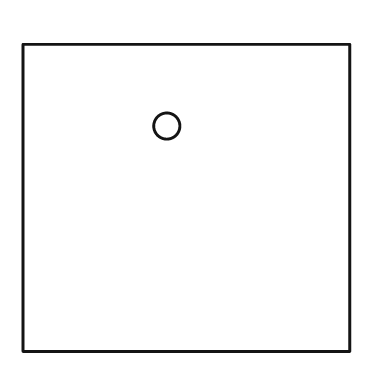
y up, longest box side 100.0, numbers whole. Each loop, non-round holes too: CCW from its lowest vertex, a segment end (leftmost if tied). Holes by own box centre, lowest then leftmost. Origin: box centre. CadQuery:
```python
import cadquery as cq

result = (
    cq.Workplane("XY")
    .moveTo(-50.0, -47.0)
    .lineTo(50.0, -47.0)
    .lineTo(50.0, 47.0)
    .lineTo(-50.0, 47.0)
    .close()
    .moveTo(-6.0, 22.0)
    .circle(4.0)
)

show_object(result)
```